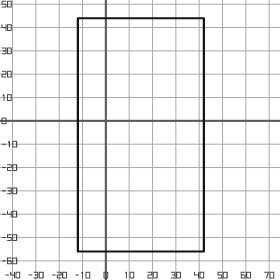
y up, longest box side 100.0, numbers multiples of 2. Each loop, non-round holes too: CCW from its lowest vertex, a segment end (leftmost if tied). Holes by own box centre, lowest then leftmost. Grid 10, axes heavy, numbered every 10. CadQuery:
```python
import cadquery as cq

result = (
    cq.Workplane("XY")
    .moveTo(-12.0, -56.0)
    .lineTo(42.0, -56.0)
    .lineTo(42.0, 44.0)
    .lineTo(-12.0, 44.0)
    .close()
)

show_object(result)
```